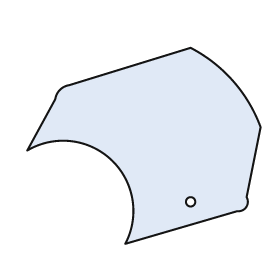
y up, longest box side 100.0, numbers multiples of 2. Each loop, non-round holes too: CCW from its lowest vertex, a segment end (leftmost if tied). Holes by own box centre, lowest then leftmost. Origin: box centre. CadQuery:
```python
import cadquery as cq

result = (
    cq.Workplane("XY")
    .moveTo(-8.0, -42.0)
    .lineTo(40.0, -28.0)
    .threePointArc((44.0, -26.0), (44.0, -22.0))
    .lineTo(50.0, 8.0)
    .threePointArc((38.0, 28.0), (20.0, 42.0))
    .lineTo(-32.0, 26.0)
    .threePointArc((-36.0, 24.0), (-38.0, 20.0))
    .lineTo(-50.0, -2.0)
    .threePointArc((-14.0, -6.0), (-8.0, -42.0))
    .close()
    .moveTo(20.0, -24.0)
    .circle(2.0)
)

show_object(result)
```